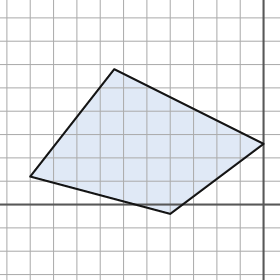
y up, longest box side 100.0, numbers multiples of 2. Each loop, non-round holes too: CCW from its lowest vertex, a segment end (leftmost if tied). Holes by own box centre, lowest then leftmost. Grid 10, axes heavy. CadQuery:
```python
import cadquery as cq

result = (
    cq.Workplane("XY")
    .moveTo(-40.0, -4.0)
    .lineTo(0.0, 26.0)
    .lineTo(-64.0, 58.0)
    .lineTo(-100.0, 12.0)
    .close()
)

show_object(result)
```